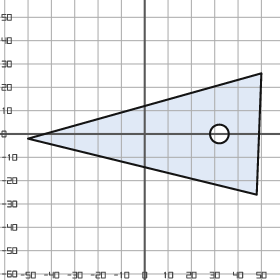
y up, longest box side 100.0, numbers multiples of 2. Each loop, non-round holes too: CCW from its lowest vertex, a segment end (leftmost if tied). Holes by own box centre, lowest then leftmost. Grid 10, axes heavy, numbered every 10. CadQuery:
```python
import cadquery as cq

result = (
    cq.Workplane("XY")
    .moveTo(48.0, -26.0)
    .lineTo(50.0, 26.0)
    .lineTo(-50.0, -2.0)
    .close()
    .moveTo(32.0, 0.0)
    .circle(4.0)
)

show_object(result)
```